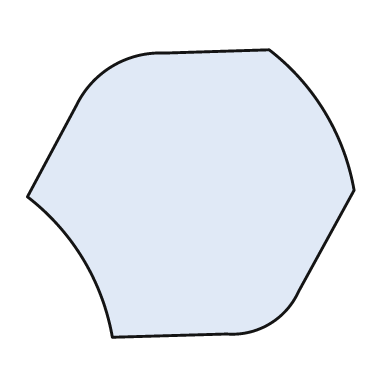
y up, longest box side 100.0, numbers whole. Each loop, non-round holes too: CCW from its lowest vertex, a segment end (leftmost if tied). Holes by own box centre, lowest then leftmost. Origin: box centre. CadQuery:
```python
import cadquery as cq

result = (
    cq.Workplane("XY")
    .moveTo(-24.0, -44.0)
    .lineTo(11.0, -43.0)
    .threePointArc((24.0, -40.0), (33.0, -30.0))
    .lineTo(50.0, 1.0)
    .threePointArc((41.0, 25.0), (24.0, 44.0))
    .lineTo(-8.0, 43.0)
    .threePointArc((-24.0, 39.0), (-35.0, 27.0))
    .lineTo(-50.0, -1.0)
    .threePointArc((-33.0, -20.0), (-24.0, -44.0))
    .close()
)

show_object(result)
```